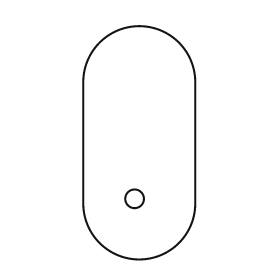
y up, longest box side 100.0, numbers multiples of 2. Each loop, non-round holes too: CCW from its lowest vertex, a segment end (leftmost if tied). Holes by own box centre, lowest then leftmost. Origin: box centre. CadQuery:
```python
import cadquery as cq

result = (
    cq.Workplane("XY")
    .moveTo(-24.0, -26.0)
    .threePointArc((0.0, -50.0), (24.0, -26.0))
    .lineTo(24.0, 26.0)
    .threePointArc((0.0, 50.0), (-24.0, 26.0))
    .close()
    .moveTo(-2.0, -24.0)
    .circle(4.0)
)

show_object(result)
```